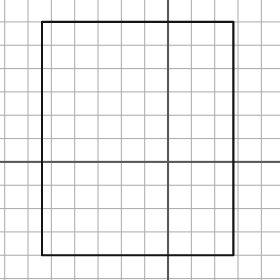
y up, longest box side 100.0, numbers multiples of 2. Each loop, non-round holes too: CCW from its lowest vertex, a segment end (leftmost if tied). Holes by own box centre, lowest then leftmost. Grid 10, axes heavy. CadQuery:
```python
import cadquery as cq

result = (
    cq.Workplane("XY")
    .moveTo(-54.0, -40.0)
    .lineTo(28.0, -40.0)
    .lineTo(28.0, 60.0)
    .lineTo(-54.0, 60.0)
    .close()
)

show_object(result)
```